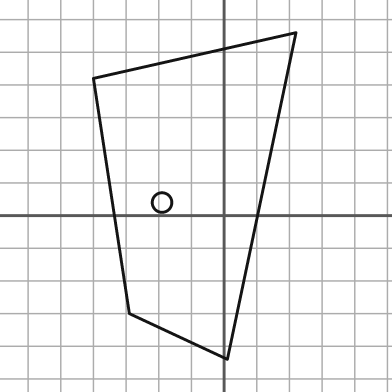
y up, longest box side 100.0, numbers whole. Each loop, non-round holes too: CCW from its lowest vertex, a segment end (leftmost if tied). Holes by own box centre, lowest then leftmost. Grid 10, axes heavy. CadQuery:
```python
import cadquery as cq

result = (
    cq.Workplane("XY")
    .moveTo(1.0, -44.0)
    .lineTo(22.0, 56.0)
    .lineTo(-40.0, 42.0)
    .lineTo(-29.0, -30.0)
    .close()
    .moveTo(-19.0, 4.0)
    .circle(3.0)
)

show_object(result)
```